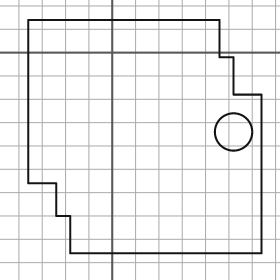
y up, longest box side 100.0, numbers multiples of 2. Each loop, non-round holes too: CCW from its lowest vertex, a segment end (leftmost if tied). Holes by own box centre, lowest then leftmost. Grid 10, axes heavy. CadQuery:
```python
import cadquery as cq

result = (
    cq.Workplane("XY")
    .moveTo(-18.0, -86.0)
    .lineTo(64.0, -86.0)
    .lineTo(64.0, -18.0)
    .lineTo(52.0, -18.0)
    .lineTo(52.0, -2.0)
    .lineTo(46.0, -2.0)
    .lineTo(46.0, 14.0)
    .lineTo(-36.0, 14.0)
    .lineTo(-36.0, -56.0)
    .lineTo(-24.0, -56.0)
    .lineTo(-24.0, -70.0)
    .lineTo(-18.0, -70.0)
    .close()
    .moveTo(52.0, -34.0)
    .circle(8.0)
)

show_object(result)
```